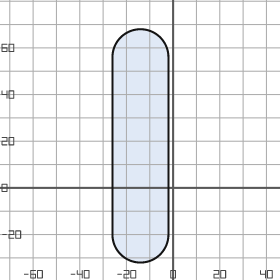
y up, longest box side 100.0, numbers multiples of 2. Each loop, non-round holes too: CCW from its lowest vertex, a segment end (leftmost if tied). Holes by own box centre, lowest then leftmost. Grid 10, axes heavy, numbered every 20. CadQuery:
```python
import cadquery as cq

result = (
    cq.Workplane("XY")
    .moveTo(-26.0, -20.0)
    .threePointArc((-14.0, -32.0), (-2.0, -20.0))
    .lineTo(-2.0, 56.0)
    .threePointArc((-14.0, 68.0), (-26.0, 56.0))
    .close()
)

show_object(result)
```